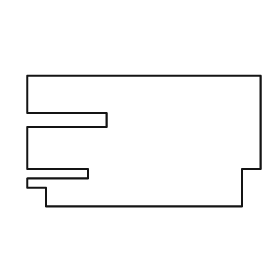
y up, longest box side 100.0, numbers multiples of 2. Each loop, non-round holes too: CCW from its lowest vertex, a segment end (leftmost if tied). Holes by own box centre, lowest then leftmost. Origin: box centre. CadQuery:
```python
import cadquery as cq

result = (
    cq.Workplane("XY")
    .moveTo(-42.0, -28.0)
    .lineTo(42.0, -28.0)
    .lineTo(42.0, -12.0)
    .lineTo(50.0, -12.0)
    .lineTo(50.0, 28.0)
    .lineTo(-50.0, 28.0)
    .lineTo(-50.0, 12.0)
    .lineTo(-16.0, 12.0)
    .lineTo(-16.0, 6.0)
    .lineTo(-50.0, 6.0)
    .lineTo(-50.0, -12.0)
    .lineTo(-24.0, -12.0)
    .lineTo(-24.0, -16.0)
    .lineTo(-50.0, -16.0)
    .lineTo(-50.0, -20.0)
    .lineTo(-42.0, -20.0)
    .close()
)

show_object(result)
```